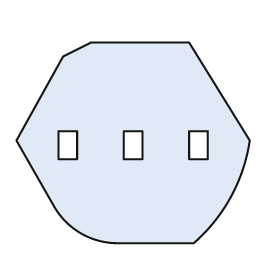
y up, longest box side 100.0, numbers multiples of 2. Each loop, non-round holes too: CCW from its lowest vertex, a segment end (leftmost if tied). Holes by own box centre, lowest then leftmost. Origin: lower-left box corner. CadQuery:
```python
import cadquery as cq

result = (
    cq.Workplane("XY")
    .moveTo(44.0, 0.0)
    .lineTo(76.0, 0.0)
    .threePointArc((92.0, 20.0), (100.0, 44.0))
    .lineTo(74.0, 86.0)
    .lineTo(32.0, 86.0)
    .lineTo(20.0, 80.0)
    .lineTo(0.0, 44.0)
    .lineTo(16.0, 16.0)
    .threePointArc((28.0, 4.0), (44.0, 0.0))
    .close()
    .moveTo(18.0, 36.0)
    .lineTo(26.0, 36.0)
    .lineTo(26.0, 48.0)
    .lineTo(18.0, 48.0)
    .close()
    .moveTo(46.0, 36.0)
    .lineTo(54.0, 36.0)
    .lineTo(54.0, 48.0)
    .lineTo(46.0, 48.0)
    .close()
    .moveTo(74.0, 36.0)
    .lineTo(82.0, 36.0)
    .lineTo(82.0, 48.0)
    .lineTo(74.0, 48.0)
    .close()
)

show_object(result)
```